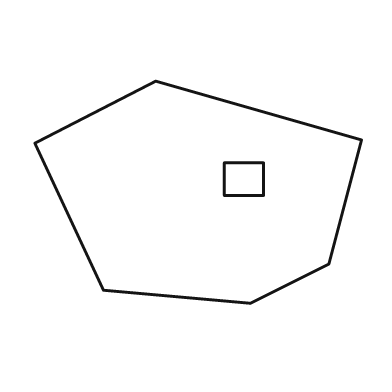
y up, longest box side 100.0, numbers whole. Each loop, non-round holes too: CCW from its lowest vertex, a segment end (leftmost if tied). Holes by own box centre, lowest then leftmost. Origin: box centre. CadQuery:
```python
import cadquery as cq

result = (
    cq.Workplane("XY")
    .moveTo(16.0, -34.0)
    .lineTo(40.0, -22.0)
    .lineTo(50.0, 16.0)
    .lineTo(-13.0, 34.0)
    .lineTo(-50.0, 15.0)
    .lineTo(-29.0, -30.0)
    .close()
    .moveTo(8.0, -1.0)
    .lineTo(20.0, -1.0)
    .lineTo(20.0, 9.0)
    .lineTo(8.0, 9.0)
    .close()
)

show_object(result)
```